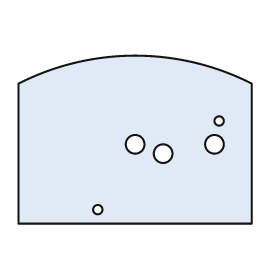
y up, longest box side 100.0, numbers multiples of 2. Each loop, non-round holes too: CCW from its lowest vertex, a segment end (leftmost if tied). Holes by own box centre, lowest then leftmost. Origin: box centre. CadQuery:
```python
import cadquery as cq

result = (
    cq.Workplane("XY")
    .moveTo(-50.0, -36.0)
    .lineTo(50.0, -36.0)
    .lineTo(50.0, 24.0)
    .threePointArc((0.0, 36.0), (-50.0, 24.0))
    .close()
    .moveTo(-16.0, -30.0)
    .circle(2.0)
    .moveTo(12.0, -6.0)
    .circle(4.0)
    .moveTo(0.0, -2.0)
    .circle(4.0)
    .moveTo(34.0, -2.0)
    .circle(4.0)
    .moveTo(36.0, 8.0)
    .circle(2.0)
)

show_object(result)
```